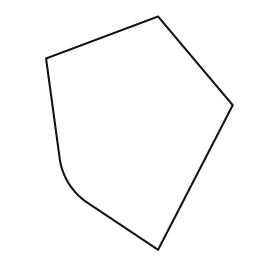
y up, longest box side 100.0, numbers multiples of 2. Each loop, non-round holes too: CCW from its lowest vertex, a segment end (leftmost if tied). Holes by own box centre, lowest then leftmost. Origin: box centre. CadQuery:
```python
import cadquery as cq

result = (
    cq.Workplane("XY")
    .moveTo(8.0, -50.0)
    .lineTo(40.0, 12.0)
    .lineTo(8.0, 50.0)
    .lineTo(-40.0, 32.0)
    .lineTo(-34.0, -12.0)
    .threePointArc((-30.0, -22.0), (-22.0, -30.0))
    .close()
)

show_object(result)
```